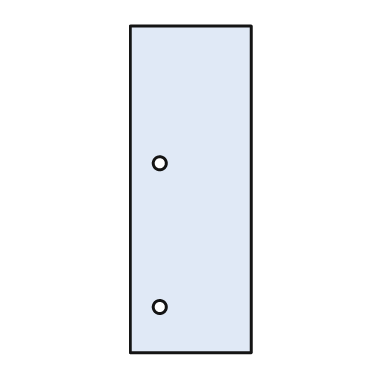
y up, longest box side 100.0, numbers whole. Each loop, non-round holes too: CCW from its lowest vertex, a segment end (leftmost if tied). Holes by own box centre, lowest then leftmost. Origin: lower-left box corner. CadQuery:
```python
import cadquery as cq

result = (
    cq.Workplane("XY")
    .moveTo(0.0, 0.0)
    .lineTo(37.0, 0.0)
    .lineTo(37.0, 100.0)
    .lineTo(0.0, 100.0)
    .close()
    .moveTo(9.0, 14.0)
    .circle(2.0)
    .moveTo(9.0, 58.0)
    .circle(2.0)
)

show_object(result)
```